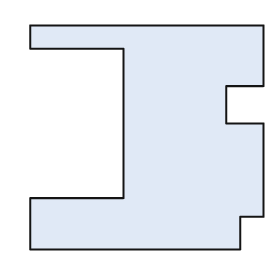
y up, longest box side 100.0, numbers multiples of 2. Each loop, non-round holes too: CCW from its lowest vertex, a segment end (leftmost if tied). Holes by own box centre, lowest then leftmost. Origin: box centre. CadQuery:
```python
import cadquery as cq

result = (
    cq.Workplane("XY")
    .moveTo(-50.0, -48.0)
    .lineTo(40.0, -48.0)
    .lineTo(40.0, -34.0)
    .lineTo(50.0, -34.0)
    .lineTo(50.0, 6.0)
    .lineTo(34.0, 6.0)
    .lineTo(34.0, 22.0)
    .lineTo(50.0, 22.0)
    .lineTo(50.0, 48.0)
    .lineTo(-50.0, 48.0)
    .lineTo(-50.0, 38.0)
    .lineTo(-10.0, 38.0)
    .lineTo(-10.0, -26.0)
    .lineTo(-50.0, -26.0)
    .close()
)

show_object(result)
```